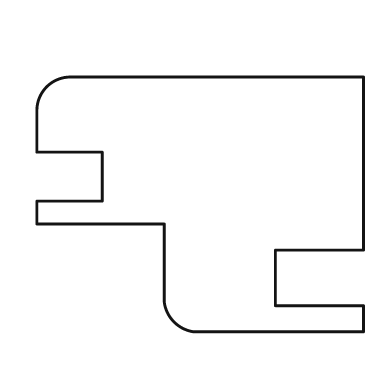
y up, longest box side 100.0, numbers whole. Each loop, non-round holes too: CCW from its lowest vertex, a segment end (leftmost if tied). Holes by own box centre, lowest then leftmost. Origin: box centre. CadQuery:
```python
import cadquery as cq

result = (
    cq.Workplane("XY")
    .moveTo(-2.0, -39.0)
    .lineTo(50.0, -39.0)
    .lineTo(50.0, -31.0)
    .lineTo(23.0, -31.0)
    .lineTo(23.0, -14.0)
    .lineTo(50.0, -14.0)
    .lineTo(50.0, 39.0)
    .lineTo(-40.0, 39.0)
    .threePointArc((-47.0, 36.0), (-50.0, 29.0))
    .lineTo(-50.0, 16.0)
    .lineTo(-30.0, 16.0)
    .lineTo(-30.0, 1.0)
    .lineTo(-50.0, 1.0)
    .lineTo(-50.0, -6.0)
    .lineTo(-11.0, -6.0)
    .lineTo(-11.0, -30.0)
    .threePointArc((-8.0, -36.0), (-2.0, -39.0))
    .close()
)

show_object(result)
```